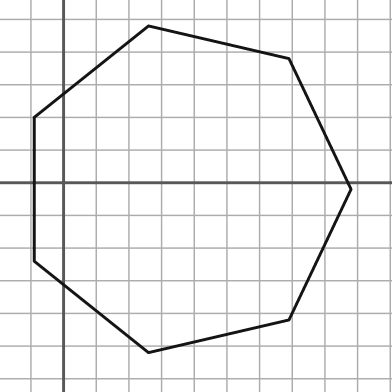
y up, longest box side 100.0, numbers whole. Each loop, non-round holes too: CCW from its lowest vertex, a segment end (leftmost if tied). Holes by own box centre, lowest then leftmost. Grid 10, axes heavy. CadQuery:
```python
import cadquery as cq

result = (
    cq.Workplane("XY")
    .moveTo(26.0, -52.0)
    .lineTo(69.0, -42.0)
    .lineTo(88.0, -2.0)
    .lineTo(69.0, 38.0)
    .lineTo(26.0, 48.0)
    .lineTo(-9.0, 20.0)
    .lineTo(-9.0, -24.0)
    .close()
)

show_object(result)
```